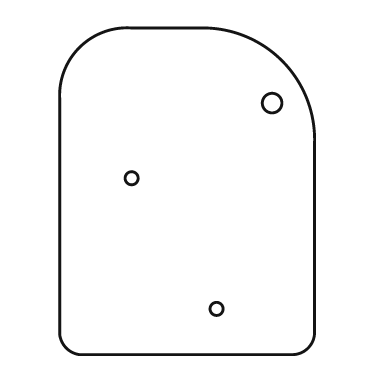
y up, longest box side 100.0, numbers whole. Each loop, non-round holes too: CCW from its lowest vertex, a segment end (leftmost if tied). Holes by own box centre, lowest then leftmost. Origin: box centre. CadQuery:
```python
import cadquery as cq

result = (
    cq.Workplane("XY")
    .moveTo(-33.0, -50.0)
    .lineTo(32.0, -50.0)
    .threePointArc((37.0, -48.0), (39.0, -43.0))
    .lineTo(39.0, 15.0)
    .threePointArc((29.0, 40.0), (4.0, 50.0))
    .lineTo(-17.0, 50.0)
    .threePointArc((-33.0, 44.0), (-39.0, 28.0))
    .lineTo(-39.0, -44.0)
    .threePointArc((-37.0, -48.0), (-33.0, -50.0))
    .close()
    .moveTo(9.0, -36.0)
    .circle(2.0)
    .moveTo(-17.0, 4.0)
    .circle(2.0)
    .moveTo(26.0, 27.0)
    .circle(3.0)
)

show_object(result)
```